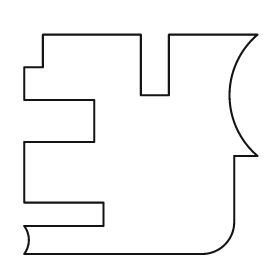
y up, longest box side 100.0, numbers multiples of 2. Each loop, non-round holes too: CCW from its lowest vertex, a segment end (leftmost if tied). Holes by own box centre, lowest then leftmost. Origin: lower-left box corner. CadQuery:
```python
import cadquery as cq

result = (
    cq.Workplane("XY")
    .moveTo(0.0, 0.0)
    .lineTo(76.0, 0.0)
    .threePointArc((86.0, 4.0), (90.0, 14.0))
    .lineTo(90.0, 42.0)
    .lineTo(100.0, 42.0)
    .threePointArc((88.0, 68.0), (100.0, 94.0))
    .lineTo(62.0, 94.0)
    .lineTo(62.0, 68.0)
    .lineTo(50.0, 68.0)
    .lineTo(50.0, 94.0)
    .lineTo(8.0, 94.0)
    .lineTo(8.0, 80.0)
    .lineTo(0.0, 80.0)
    .lineTo(0.0, 66.0)
    .lineTo(30.0, 66.0)
    .lineTo(30.0, 48.0)
    .lineTo(0.0, 48.0)
    .lineTo(0.0, 22.0)
    .lineTo(34.0, 22.0)
    .lineTo(34.0, 12.0)
    .lineTo(0.0, 12.0)
    .threePointArc((2.0, 6.0), (0.0, 0.0))
    .close()
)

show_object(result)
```